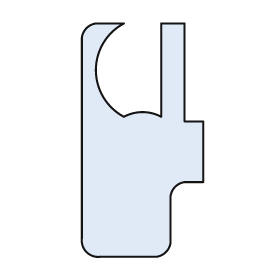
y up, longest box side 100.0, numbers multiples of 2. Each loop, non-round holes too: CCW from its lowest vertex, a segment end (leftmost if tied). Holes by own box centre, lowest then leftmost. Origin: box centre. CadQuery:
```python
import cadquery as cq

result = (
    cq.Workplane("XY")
    .moveTo(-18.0, -50.0)
    .lineTo(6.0, -50.0)
    .threePointArc((10.0, -48.0), (12.0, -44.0))
    .lineTo(12.0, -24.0)
    .threePointArc((14.0, -20.0), (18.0, -18.0))
    .lineTo(26.0, -18.0)
    .lineTo(26.0, 8.0)
    .lineTo(18.0, 8.0)
    .lineTo(18.0, 50.0)
    .lineTo(8.0, 50.0)
    .lineTo(8.0, 10.0)
    .threePointArc((0.0, 12.0), (-8.0, 10.0))
    .threePointArc((-20.0, 30.0), (-8.0, 50.0))
    .lineTo(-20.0, 50.0)
    .threePointArc((-24.0, 48.0), (-26.0, 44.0))
    .lineTo(-26.0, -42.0)
    .threePointArc((-24.0, -48.0), (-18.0, -50.0))
    .close()
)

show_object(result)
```